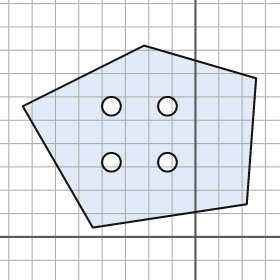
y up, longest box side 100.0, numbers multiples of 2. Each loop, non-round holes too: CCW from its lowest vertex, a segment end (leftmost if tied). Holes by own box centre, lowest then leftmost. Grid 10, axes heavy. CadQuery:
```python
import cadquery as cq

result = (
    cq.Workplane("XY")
    .moveTo(-44.0, 4.0)
    .lineTo(22.0, 14.0)
    .lineTo(26.0, 68.0)
    .lineTo(-22.0, 82.0)
    .lineTo(-74.0, 56.0)
    .close()
    .moveTo(-36.0, 32.0)
    .circle(4.0)
    .moveTo(-12.0, 32.0)
    .circle(4.0)
    .moveTo(-36.0, 56.0)
    .circle(4.0)
    .moveTo(-12.0, 56.0)
    .circle(4.0)
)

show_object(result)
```